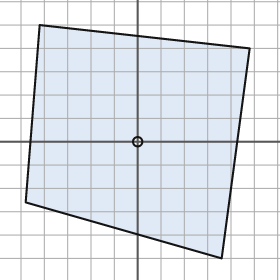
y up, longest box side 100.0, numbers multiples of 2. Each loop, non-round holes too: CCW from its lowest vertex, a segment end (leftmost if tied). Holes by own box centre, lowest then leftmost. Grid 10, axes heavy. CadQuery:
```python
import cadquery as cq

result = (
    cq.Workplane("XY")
    .moveTo(36.0, -50.0)
    .lineTo(48.0, 40.0)
    .lineTo(-42.0, 50.0)
    .lineTo(-48.0, -26.0)
    .close()
    .moveTo(0.0, 0.0)
    .circle(2.0)
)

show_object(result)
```